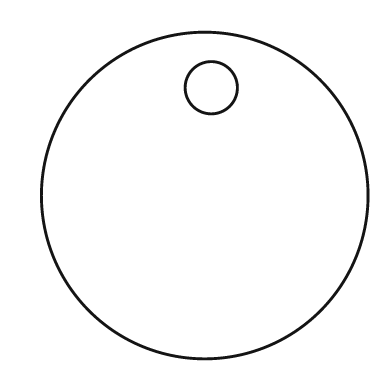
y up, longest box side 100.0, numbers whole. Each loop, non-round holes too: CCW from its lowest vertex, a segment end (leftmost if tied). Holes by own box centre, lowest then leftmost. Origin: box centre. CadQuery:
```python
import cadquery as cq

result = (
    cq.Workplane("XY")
    .moveTo(0.0, 0.0)
    .circle(50.0)
    .moveTo(2.0, 33.0)
    .circle(8.0)
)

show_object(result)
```